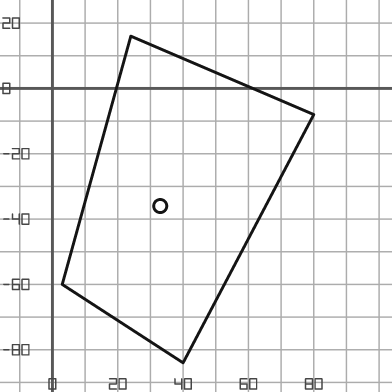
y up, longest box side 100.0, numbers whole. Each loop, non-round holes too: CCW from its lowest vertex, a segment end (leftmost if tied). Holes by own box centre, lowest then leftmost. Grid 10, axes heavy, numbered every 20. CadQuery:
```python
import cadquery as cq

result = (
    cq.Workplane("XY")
    .moveTo(40.0, -84.0)
    .lineTo(80.0, -8.0)
    .lineTo(24.0, 16.0)
    .lineTo(3.0, -60.0)
    .close()
    .moveTo(33.0, -36.0)
    .circle(2.0)
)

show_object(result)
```